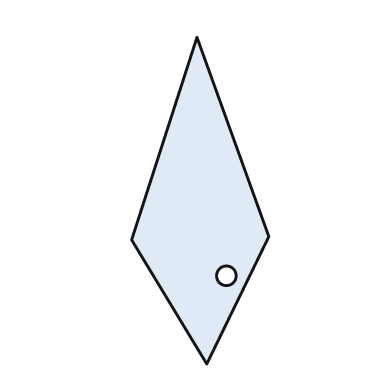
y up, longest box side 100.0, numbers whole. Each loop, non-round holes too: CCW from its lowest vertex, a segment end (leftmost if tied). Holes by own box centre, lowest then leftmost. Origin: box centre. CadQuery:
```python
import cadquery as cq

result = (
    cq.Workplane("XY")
    .moveTo(2.0, -50.0)
    .lineTo(21.0, -11.0)
    .lineTo(-1.0, 50.0)
    .lineTo(-21.0, -12.0)
    .close()
    .moveTo(8.0, -23.0)
    .circle(3.0)
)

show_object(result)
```